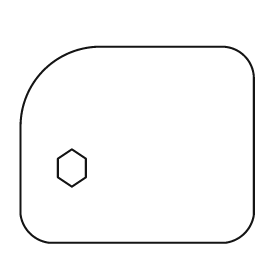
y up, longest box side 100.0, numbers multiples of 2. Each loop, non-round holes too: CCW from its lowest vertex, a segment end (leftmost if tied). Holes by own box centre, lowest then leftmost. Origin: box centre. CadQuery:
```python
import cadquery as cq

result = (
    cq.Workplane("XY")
    .moveTo(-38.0, -42.0)
    .lineTo(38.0, -42.0)
    .threePointArc((46.0, -38.0), (50.0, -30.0))
    .lineTo(50.0, 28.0)
    .threePointArc((46.0, 38.0), (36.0, 42.0))
    .lineTo(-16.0, 42.0)
    .threePointArc((-40.0, 32.0), (-50.0, 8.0))
    .lineTo(-50.0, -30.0)
    .threePointArc((-46.0, -38.0), (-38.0, -42.0))
    .close()
    .moveTo(-28.0, -18.0)
    .lineTo(-22.0, -14.0)
    .lineTo(-22.0, -6.0)
    .lineTo(-28.0, -2.0)
    .lineTo(-34.0, -6.0)
    .lineTo(-34.0, -14.0)
    .close()
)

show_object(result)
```